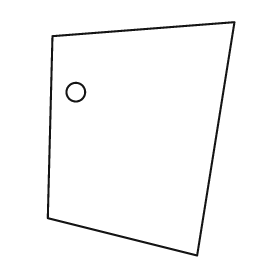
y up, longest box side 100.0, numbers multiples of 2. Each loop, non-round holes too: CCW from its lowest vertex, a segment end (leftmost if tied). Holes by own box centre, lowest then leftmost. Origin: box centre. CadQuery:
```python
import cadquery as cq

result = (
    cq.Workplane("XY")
    .moveTo(24.0, -50.0)
    .lineTo(40.0, 50.0)
    .lineTo(-38.0, 44.0)
    .lineTo(-40.0, -34.0)
    .close()
    .moveTo(-28.0, 20.0)
    .circle(4.0)
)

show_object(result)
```